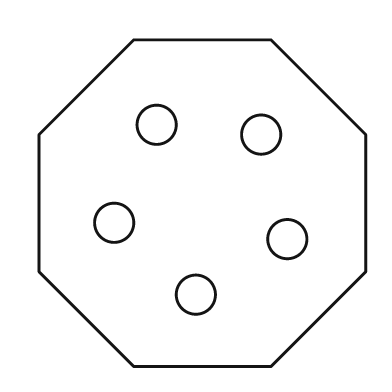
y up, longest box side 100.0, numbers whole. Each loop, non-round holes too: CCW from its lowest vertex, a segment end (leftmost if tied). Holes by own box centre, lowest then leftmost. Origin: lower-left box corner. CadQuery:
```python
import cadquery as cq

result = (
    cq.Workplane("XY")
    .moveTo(29.0, 0.0)
    .lineTo(71.0, 0.0)
    .lineTo(100.0, 29.0)
    .lineTo(100.0, 71.0)
    .lineTo(71.0, 100.0)
    .lineTo(29.0, 100.0)
    .lineTo(0.0, 71.0)
    .lineTo(0.0, 29.0)
    .close()
    .moveTo(48.0, 22.0)
    .circle(6.0)
    .moveTo(76.0, 39.0)
    .circle(6.0)
    .moveTo(23.0, 44.0)
    .circle(6.0)
    .moveTo(68.0, 71.0)
    .circle(6.0)
    .moveTo(36.0, 74.0)
    .circle(6.0)
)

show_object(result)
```